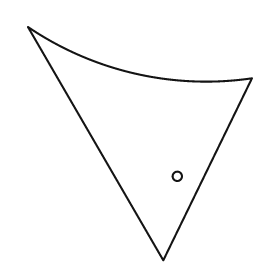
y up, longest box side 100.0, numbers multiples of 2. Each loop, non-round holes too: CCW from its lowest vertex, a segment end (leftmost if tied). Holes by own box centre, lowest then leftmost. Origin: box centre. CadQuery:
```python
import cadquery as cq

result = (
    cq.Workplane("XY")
    .moveTo(10.0, -50.0)
    .lineTo(48.0, 28.0)
    .threePointArc((-2.0, 30.0), (-48.0, 50.0))
    .close()
    .moveTo(16.0, -14.0)
    .circle(2.0)
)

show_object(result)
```